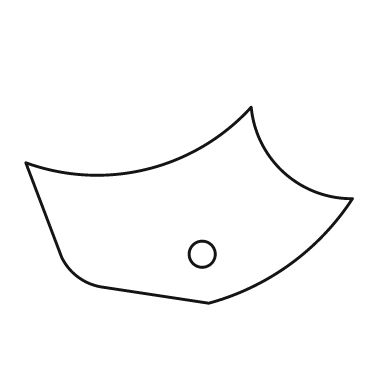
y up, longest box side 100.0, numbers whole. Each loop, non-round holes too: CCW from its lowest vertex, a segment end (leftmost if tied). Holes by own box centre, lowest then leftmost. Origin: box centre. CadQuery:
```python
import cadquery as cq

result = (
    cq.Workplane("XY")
    .moveTo(6.0, -30.0)
    .threePointArc((31.0, -18.0), (50.0, 2.0))
    .threePointArc((29.0, 10.0), (19.0, 30.0))
    .threePointArc((-13.0, 11.0), (-50.0, 13.0))
    .lineTo(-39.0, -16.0)
    .threePointArc((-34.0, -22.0), (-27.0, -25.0))
    .close()
    .moveTo(4.0, -15.0)
    .circle(4.0)
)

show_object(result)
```